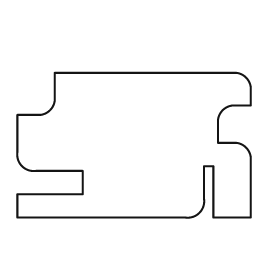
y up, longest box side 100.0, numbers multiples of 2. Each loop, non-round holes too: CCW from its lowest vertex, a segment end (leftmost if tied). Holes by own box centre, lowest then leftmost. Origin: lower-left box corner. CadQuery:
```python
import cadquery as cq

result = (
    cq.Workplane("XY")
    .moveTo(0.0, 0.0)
    .lineTo(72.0, 0.0)
    .threePointArc((78.0, 2.0), (80.0, 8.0))
    .lineTo(80.0, 22.0)
    .lineTo(84.0, 22.0)
    .lineTo(84.0, 0.0)
    .lineTo(100.0, 0.0)
    .lineTo(100.0, 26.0)
    .threePointArc((98.0, 30.0), (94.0, 32.0))
    .lineTo(86.0, 32.0)
    .lineTo(86.0, 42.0)
    .threePointArc((88.0, 46.0), (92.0, 48.0))
    .lineTo(100.0, 48.0)
    .lineTo(100.0, 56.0)
    .threePointArc((98.0, 60.0), (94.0, 62.0))
    .lineTo(16.0, 62.0)
    .lineTo(16.0, 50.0)
    .threePointArc((14.0, 46.0), (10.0, 44.0))
    .lineTo(0.0, 44.0)
    .lineTo(0.0, 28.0)
    .threePointArc((2.0, 22.0), (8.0, 20.0))
    .lineTo(28.0, 20.0)
    .lineTo(28.0, 10.0)
    .lineTo(0.0, 10.0)
    .close()
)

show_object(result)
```